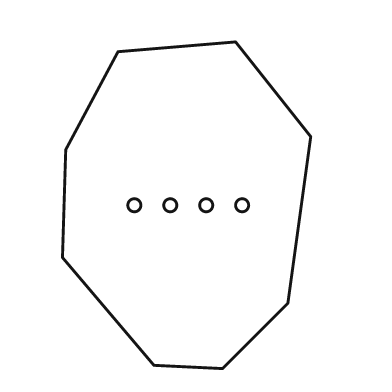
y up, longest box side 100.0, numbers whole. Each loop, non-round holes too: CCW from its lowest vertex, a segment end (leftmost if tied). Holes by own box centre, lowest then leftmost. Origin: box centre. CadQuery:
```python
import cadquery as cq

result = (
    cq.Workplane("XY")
    .moveTo(11.0, -50.0)
    .lineTo(31.0, -30.0)
    .lineTo(38.0, 21.0)
    .lineTo(15.0, 50.0)
    .lineTo(-21.0, 47.0)
    .lineTo(-37.0, 17.0)
    .lineTo(-38.0, -16.0)
    .lineTo(-10.0, -49.0)
    .close()
    .moveTo(-16.0, 0.0)
    .circle(2.0)
    .moveTo(-5.0, 0.0)
    .circle(2.0)
    .moveTo(6.0, 0.0)
    .circle(2.0)
    .moveTo(17.0, 0.0)
    .circle(2.0)
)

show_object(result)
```